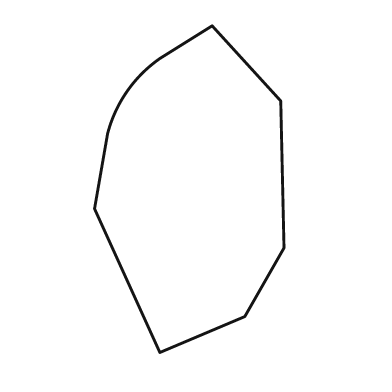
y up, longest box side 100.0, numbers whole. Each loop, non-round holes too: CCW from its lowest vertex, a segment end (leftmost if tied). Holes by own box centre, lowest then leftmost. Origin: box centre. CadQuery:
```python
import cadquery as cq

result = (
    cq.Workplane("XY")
    .moveTo(-9.0, -50.0)
    .lineTo(17.0, -39.0)
    .lineTo(29.0, -18.0)
    .lineTo(28.0, 27.0)
    .lineTo(7.0, 50.0)
    .lineTo(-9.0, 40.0)
    .threePointArc((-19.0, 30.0), (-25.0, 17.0))
    .lineTo(-29.0, -6.0)
    .close()
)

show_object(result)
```